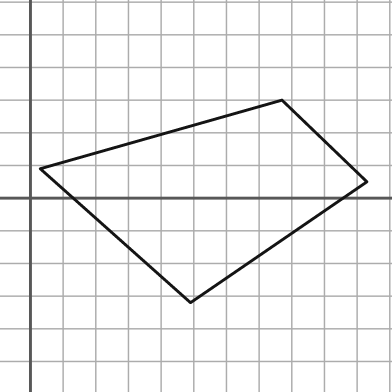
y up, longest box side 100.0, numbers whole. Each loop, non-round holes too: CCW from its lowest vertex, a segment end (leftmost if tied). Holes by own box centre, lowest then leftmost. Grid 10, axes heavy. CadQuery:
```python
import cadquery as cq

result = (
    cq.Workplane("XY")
    .moveTo(49.0, -32.0)
    .lineTo(103.0, 5.0)
    .lineTo(77.0, 30.0)
    .lineTo(3.0, 9.0)
    .close()
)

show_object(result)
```